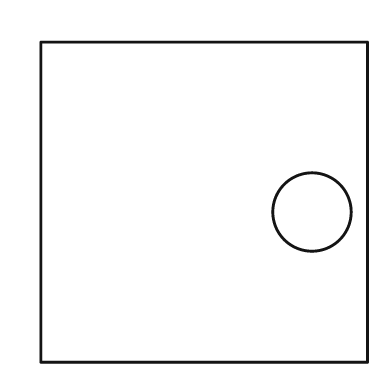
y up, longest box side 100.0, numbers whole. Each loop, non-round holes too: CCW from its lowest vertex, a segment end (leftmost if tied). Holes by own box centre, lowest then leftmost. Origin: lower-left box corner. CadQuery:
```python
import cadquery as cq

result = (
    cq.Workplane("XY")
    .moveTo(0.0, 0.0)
    .lineTo(100.0, 0.0)
    .lineTo(100.0, 98.0)
    .lineTo(0.0, 98.0)
    .close()
    .moveTo(83.0, 46.0)
    .circle(12.0)
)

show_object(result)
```